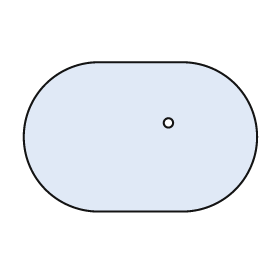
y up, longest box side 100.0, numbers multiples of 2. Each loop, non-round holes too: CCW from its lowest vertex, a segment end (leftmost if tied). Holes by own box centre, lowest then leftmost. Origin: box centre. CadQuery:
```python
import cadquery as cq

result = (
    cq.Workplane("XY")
    .moveTo(-18.0, -32.0)
    .lineTo(18.0, -32.0)
    .threePointArc((50.0, 0.0), (18.0, 32.0))
    .lineTo(-18.0, 32.0)
    .threePointArc((-50.0, 0.0), (-18.0, -32.0))
    .close()
    .moveTo(12.0, 6.0)
    .circle(2.0)
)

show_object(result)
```